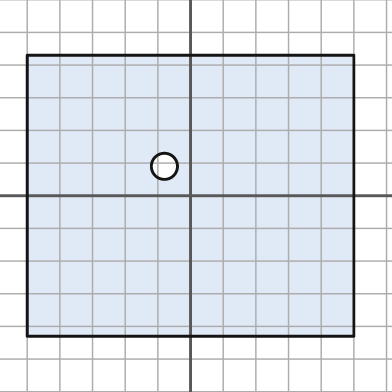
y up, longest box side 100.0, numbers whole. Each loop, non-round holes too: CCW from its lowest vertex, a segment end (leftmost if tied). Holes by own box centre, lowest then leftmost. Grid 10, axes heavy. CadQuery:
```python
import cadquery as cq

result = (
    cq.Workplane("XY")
    .moveTo(-50.0, -43.0)
    .lineTo(50.0, -43.0)
    .lineTo(50.0, 43.0)
    .lineTo(-50.0, 43.0)
    .close()
    .moveTo(-8.0, 9.0)
    .circle(4.0)
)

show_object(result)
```